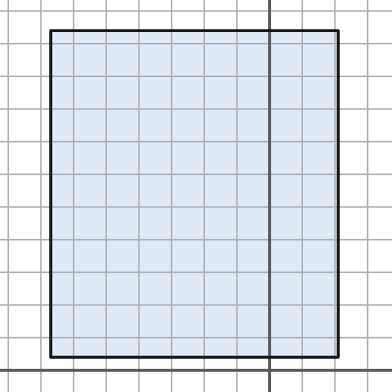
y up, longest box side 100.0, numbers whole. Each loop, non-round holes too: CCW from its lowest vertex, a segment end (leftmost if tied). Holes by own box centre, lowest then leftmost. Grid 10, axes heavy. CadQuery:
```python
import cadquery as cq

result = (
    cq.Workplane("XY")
    .moveTo(-67.0, 4.0)
    .lineTo(21.0, 4.0)
    .lineTo(21.0, 104.0)
    .lineTo(-67.0, 104.0)
    .close()
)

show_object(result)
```